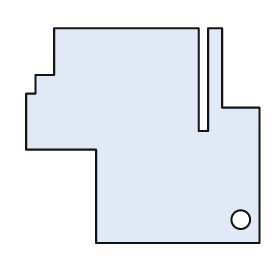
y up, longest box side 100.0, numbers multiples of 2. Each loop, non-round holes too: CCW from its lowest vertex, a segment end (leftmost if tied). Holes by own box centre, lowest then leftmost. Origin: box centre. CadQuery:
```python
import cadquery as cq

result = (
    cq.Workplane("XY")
    .moveTo(-20.0, -46.0)
    .lineTo(50.0, -46.0)
    .lineTo(50.0, 12.0)
    .lineTo(34.0, 12.0)
    .lineTo(34.0, 46.0)
    .lineTo(28.0, 46.0)
    .lineTo(28.0, 2.0)
    .lineTo(24.0, 2.0)
    .lineTo(24.0, 46.0)
    .lineTo(-38.0, 46.0)
    .lineTo(-38.0, 26.0)
    .lineTo(-46.0, 26.0)
    .lineTo(-46.0, 18.0)
    .lineTo(-50.0, 18.0)
    .lineTo(-50.0, -6.0)
    .lineTo(-20.0, -6.0)
    .close()
    .moveTo(42.0, -36.0)
    .circle(4.0)
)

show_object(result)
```